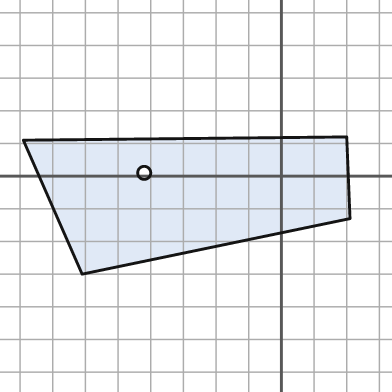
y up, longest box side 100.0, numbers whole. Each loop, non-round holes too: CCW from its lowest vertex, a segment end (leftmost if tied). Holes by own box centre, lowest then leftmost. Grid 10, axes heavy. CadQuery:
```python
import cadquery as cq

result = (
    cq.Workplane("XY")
    .moveTo(-61.0, -30.0)
    .lineTo(21.0, -13.0)
    .lineTo(20.0, 12.0)
    .lineTo(-79.0, 11.0)
    .close()
    .moveTo(-42.0, 1.0)
    .circle(2.0)
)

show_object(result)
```